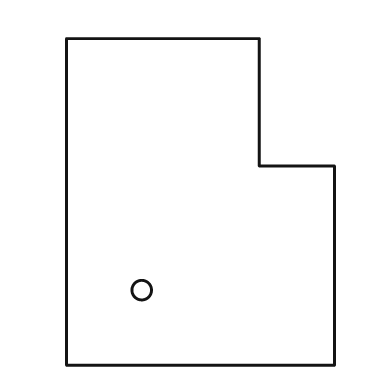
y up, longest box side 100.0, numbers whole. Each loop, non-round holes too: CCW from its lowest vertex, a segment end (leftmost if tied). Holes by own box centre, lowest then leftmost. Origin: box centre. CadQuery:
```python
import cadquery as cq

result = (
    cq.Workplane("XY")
    .moveTo(-41.0, -50.0)
    .lineTo(41.0, -50.0)
    .lineTo(41.0, 11.0)
    .lineTo(18.0, 11.0)
    .lineTo(18.0, 50.0)
    .lineTo(-41.0, 50.0)
    .close()
    .moveTo(-18.0, -27.0)
    .circle(3.0)
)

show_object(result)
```